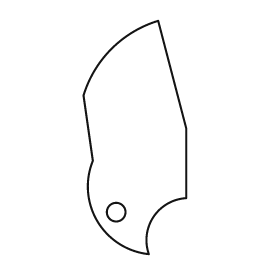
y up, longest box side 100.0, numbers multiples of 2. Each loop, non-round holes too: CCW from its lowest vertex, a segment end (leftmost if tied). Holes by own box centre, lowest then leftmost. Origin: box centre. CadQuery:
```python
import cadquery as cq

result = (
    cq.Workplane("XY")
    .moveTo(6.0, -50.0)
    .threePointArc((8.0, -34.0), (22.0, -26.0))
    .lineTo(22.0, 4.0)
    .lineTo(10.0, 50.0)
    .threePointArc((-10.0, 38.0), (-22.0, 18.0))
    .lineTo(-18.0, -10.0)
    .threePointArc((-16.0, -36.0), (6.0, -50.0))
    .close()
    .moveTo(-8.0, -32.0)
    .circle(4.0)
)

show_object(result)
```